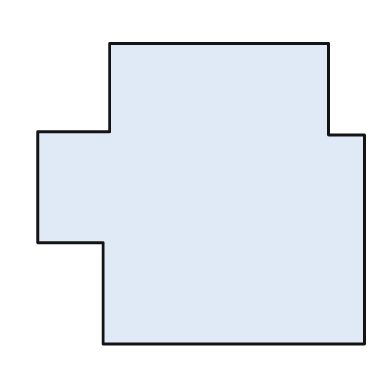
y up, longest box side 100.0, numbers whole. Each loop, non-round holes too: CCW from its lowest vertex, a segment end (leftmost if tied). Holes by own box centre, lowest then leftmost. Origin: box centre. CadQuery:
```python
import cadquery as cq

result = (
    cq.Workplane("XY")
    .moveTo(-30.0, -46.0)
    .lineTo(50.0, -46.0)
    .lineTo(50.0, 18.0)
    .lineTo(39.0, 18.0)
    .lineTo(39.0, 46.0)
    .lineTo(-28.0, 46.0)
    .lineTo(-28.0, 19.0)
    .lineTo(-50.0, 19.0)
    .lineTo(-50.0, -15.0)
    .lineTo(-30.0, -15.0)
    .close()
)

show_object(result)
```